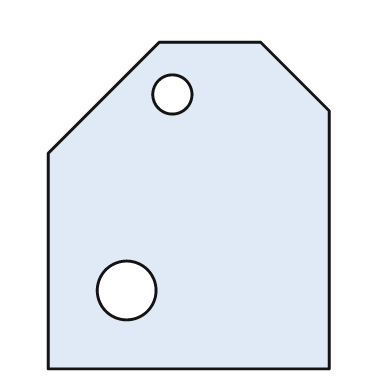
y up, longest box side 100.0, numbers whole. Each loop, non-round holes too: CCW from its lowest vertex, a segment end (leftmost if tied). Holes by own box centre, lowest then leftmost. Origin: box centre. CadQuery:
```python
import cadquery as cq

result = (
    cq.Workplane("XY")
    .moveTo(-43.0, -50.0)
    .lineTo(43.0, -50.0)
    .lineTo(43.0, 29.0)
    .lineTo(22.0, 50.0)
    .lineTo(-9.0, 50.0)
    .lineTo(-43.0, 16.0)
    .close()
    .moveTo(-19.0, -26.0)
    .circle(9.0)
    .moveTo(-5.0, 34.0)
    .circle(6.0)
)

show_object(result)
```